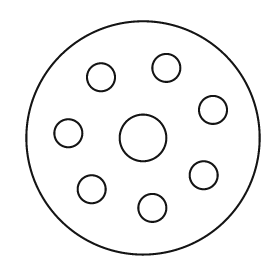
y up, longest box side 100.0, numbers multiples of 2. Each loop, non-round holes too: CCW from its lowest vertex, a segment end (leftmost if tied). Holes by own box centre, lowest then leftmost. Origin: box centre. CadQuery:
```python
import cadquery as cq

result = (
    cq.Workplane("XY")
    .moveTo(0.0, 0.0)
    .circle(50.0)
    .moveTo(4.0, -30.0)
    .circle(6.0)
    .moveTo(-22.0, -22.0)
    .circle(6.0)
    .moveTo(26.0, -16.0)
    .circle(6.0)
    .moveTo(0.0, 0.0)
    .circle(10.0)
    .moveTo(-32.0, 2.0)
    .circle(6.0)
    .moveTo(30.0, 12.0)
    .circle(6.0)
    .moveTo(-18.0, 26.0)
    .circle(6.0)
    .moveTo(10.0, 30.0)
    .circle(6.0)
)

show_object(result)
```